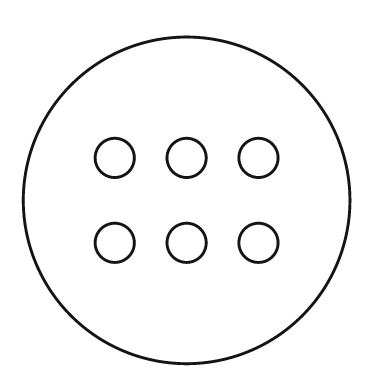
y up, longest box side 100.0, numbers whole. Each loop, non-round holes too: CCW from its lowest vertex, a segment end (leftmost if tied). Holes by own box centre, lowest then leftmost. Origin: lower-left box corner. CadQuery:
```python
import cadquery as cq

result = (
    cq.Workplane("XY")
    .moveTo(50.0, 50.0)
    .circle(50.0)
    .moveTo(28.0, 37.0)
    .circle(6.0)
    .moveTo(50.0, 37.0)
    .circle(6.0)
    .moveTo(72.0, 37.0)
    .circle(6.0)
    .moveTo(28.0, 63.0)
    .circle(6.0)
    .moveTo(50.0, 63.0)
    .circle(6.0)
    .moveTo(72.0, 63.0)
    .circle(6.0)
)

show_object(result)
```